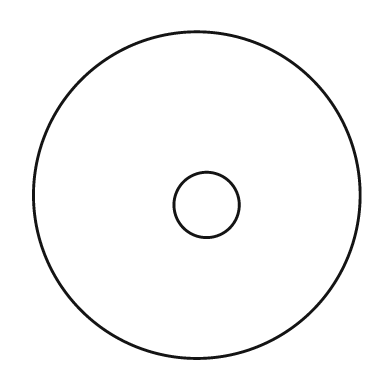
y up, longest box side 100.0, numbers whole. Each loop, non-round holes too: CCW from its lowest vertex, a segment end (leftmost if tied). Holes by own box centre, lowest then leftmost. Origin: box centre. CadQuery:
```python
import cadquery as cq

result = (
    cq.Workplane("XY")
    .moveTo(0.0, 0.0)
    .circle(50.0)
    .moveTo(3.0, -3.0)
    .circle(10.0)
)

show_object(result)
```